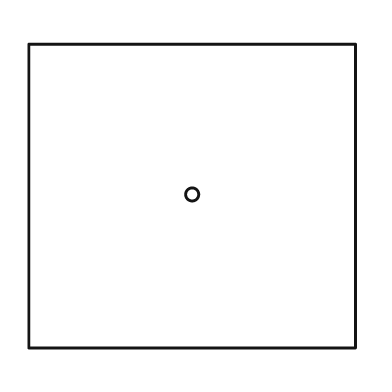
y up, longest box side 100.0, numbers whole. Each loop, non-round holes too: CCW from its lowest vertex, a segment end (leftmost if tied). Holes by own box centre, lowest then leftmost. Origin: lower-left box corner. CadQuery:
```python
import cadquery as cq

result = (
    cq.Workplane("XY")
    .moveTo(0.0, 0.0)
    .lineTo(100.0, 0.0)
    .lineTo(100.0, 93.0)
    .lineTo(0.0, 93.0)
    .close()
    .moveTo(50.0, 47.0)
    .circle(2.0)
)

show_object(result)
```